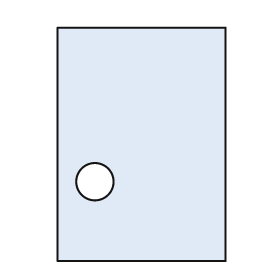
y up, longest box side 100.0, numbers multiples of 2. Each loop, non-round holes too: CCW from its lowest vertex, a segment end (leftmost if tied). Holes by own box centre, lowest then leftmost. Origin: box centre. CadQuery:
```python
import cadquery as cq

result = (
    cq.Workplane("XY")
    .moveTo(-36.0, -50.0)
    .lineTo(36.0, -50.0)
    .lineTo(36.0, 50.0)
    .lineTo(-36.0, 50.0)
    .close()
    .moveTo(-20.0, -16.0)
    .circle(8.0)
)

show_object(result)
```